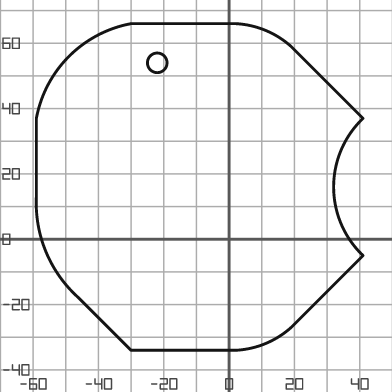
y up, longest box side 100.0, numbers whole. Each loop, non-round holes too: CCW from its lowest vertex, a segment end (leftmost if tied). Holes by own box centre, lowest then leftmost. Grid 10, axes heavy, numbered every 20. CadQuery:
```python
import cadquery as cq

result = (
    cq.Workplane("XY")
    .moveTo(-30.0, -34.0)
    .lineTo(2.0, -34.0)
    .threePointArc((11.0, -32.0), (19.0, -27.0))
    .lineTo(41.0, -5.0)
    .threePointArc((32.0, 16.0), (41.0, 37.0))
    .lineTo(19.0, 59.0)
    .threePointArc((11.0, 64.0), (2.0, 66.0))
    .lineTo(-30.0, 66.0)
    .threePointArc((-49.0, 56.0), (-59.0, 37.0))
    .lineTo(-59.0, 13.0)
    .threePointArc((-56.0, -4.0), (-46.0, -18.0))
    .close()
    .moveTo(-22.0, 54.0)
    .circle(3.0)
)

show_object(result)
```